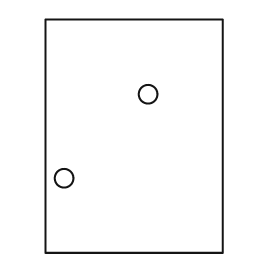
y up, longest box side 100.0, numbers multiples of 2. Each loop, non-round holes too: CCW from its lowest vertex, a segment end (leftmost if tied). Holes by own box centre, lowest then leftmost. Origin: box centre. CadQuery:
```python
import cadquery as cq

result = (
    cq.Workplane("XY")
    .moveTo(-38.0, -50.0)
    .lineTo(38.0, -50.0)
    .lineTo(38.0, 50.0)
    .lineTo(-38.0, 50.0)
    .close()
    .moveTo(-30.0, -18.0)
    .circle(4.0)
    .moveTo(6.0, 18.0)
    .circle(4.0)
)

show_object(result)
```